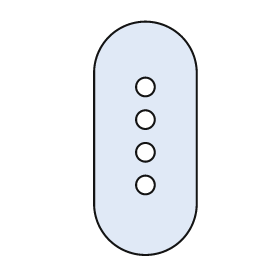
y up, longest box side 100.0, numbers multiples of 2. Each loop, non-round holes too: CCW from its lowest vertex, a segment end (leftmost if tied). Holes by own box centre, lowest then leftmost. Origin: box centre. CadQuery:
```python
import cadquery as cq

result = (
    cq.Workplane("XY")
    .moveTo(-22.0, -28.0)
    .threePointArc((0.0, -50.0), (22.0, -28.0))
    .lineTo(22.0, 28.0)
    .threePointArc((0.0, 50.0), (-22.0, 28.0))
    .close()
    .moveTo(0.0, -20.0)
    .circle(4.0)
    .moveTo(0.0, -6.0)
    .circle(4.0)
    .moveTo(0.0, 8.0)
    .circle(4.0)
    .moveTo(0.0, 22.0)
    .circle(4.0)
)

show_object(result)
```